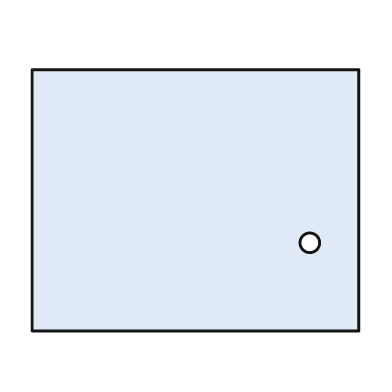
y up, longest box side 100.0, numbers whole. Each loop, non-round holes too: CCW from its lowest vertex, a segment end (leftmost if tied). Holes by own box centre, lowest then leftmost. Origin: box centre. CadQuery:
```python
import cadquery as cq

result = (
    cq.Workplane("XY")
    .moveTo(-50.0, -40.0)
    .lineTo(50.0, -40.0)
    .lineTo(50.0, 40.0)
    .lineTo(-50.0, 40.0)
    .close()
    .moveTo(35.0, -13.0)
    .circle(3.0)
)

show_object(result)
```